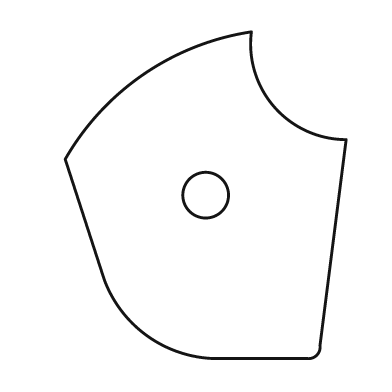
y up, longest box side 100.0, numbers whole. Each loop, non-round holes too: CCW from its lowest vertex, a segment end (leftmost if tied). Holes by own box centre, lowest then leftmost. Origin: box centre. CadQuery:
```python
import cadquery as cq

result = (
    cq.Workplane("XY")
    .moveTo(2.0, -50.0)
    .lineTo(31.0, -50.0)
    .threePointArc((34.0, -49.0), (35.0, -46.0))
    .lineTo(43.0, 17.0)
    .threePointArc((21.0, 27.0), (14.0, 50.0))
    .threePointArc((-19.0, 37.0), (-43.0, 11.0))
    .lineTo(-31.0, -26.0)
    .threePointArc((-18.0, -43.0), (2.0, -50.0))
    .close()
    .moveTo(0.0, 0.0)
    .circle(7.0)
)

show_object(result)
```